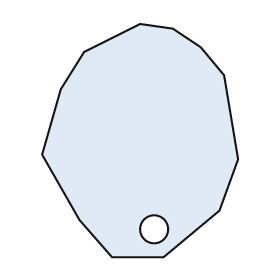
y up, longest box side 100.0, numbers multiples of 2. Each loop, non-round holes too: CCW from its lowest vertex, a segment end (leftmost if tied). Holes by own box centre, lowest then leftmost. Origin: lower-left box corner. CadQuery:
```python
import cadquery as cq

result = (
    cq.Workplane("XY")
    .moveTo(30.0, 0.0)
    .lineTo(52.0, 0.0)
    .lineTo(76.0, 20.0)
    .lineTo(84.0, 42.0)
    .lineTo(78.0, 78.0)
    .lineTo(68.0, 90.0)
    .lineTo(56.0, 98.0)
    .lineTo(42.0, 100.0)
    .lineTo(18.0, 88.0)
    .lineTo(8.0, 72.0)
    .lineTo(0.0, 44.0)
    .lineTo(16.0, 16.0)
    .close()
    .moveTo(48.0, 12.0)
    .circle(6.0)
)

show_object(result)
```